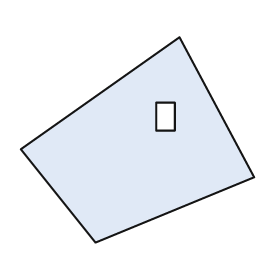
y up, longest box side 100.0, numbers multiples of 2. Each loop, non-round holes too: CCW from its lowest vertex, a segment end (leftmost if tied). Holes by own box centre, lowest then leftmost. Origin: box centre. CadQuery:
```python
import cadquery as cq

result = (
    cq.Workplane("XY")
    .moveTo(-18.0, -44.0)
    .lineTo(50.0, -16.0)
    .lineTo(18.0, 44.0)
    .lineTo(-50.0, -4.0)
    .close()
    .moveTo(8.0, 4.0)
    .lineTo(16.0, 4.0)
    .lineTo(16.0, 16.0)
    .lineTo(8.0, 16.0)
    .close()
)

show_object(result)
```